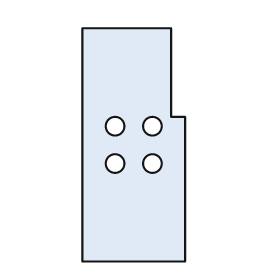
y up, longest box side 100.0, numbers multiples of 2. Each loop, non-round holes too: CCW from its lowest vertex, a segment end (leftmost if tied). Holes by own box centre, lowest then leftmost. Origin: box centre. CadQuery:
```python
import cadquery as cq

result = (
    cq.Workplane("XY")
    .moveTo(-22.0, -50.0)
    .lineTo(22.0, -50.0)
    .lineTo(22.0, 12.0)
    .lineTo(16.0, 12.0)
    .lineTo(16.0, 50.0)
    .lineTo(-22.0, 50.0)
    .close()
    .moveTo(-8.0, -8.0)
    .circle(4.0)
    .moveTo(8.0, -8.0)
    .circle(4.0)
    .moveTo(-8.0, 8.0)
    .circle(4.0)
    .moveTo(8.0, 8.0)
    .circle(4.0)
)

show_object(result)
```